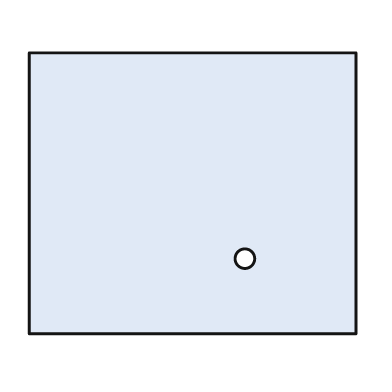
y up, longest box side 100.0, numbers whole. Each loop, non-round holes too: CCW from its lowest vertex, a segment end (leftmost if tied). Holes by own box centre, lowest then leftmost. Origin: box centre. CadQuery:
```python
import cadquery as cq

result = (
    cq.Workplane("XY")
    .moveTo(-50.0, -43.0)
    .lineTo(50.0, -43.0)
    .lineTo(50.0, 43.0)
    .lineTo(-50.0, 43.0)
    .close()
    .moveTo(16.0, -20.0)
    .circle(3.0)
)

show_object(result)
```